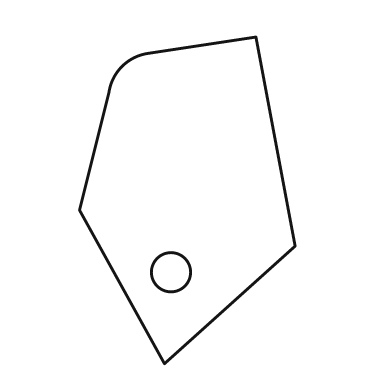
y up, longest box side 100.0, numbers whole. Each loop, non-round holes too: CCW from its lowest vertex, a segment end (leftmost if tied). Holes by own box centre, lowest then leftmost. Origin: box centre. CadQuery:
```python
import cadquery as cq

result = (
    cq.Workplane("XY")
    .moveTo(-7.0, -50.0)
    .lineTo(33.0, -14.0)
    .lineTo(21.0, 50.0)
    .lineTo(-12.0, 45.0)
    .threePointArc((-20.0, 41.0), (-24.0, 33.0))
    .lineTo(-33.0, -3.0)
    .close()
    .moveTo(-5.0, -22.0)
    .circle(6.0)
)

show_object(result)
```